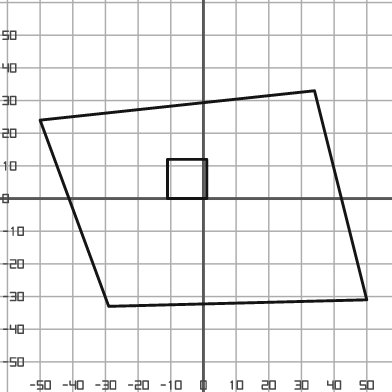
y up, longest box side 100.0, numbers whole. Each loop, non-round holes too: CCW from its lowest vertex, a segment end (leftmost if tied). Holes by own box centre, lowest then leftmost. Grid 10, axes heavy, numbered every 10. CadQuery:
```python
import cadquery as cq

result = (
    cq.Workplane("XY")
    .moveTo(-29.0, -33.0)
    .lineTo(50.0, -31.0)
    .lineTo(34.0, 33.0)
    .lineTo(-50.0, 24.0)
    .close()
    .moveTo(-11.0, 0.0)
    .lineTo(1.0, 0.0)
    .lineTo(1.0, 12.0)
    .lineTo(-11.0, 12.0)
    .close()
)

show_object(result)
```